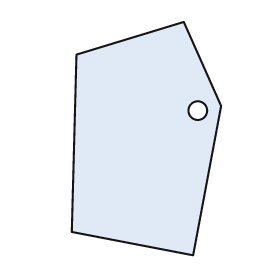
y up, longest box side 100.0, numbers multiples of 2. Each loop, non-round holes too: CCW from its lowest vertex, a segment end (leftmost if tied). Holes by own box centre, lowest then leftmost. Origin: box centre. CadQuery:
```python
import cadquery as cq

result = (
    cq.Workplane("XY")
    .moveTo(20.0, -50.0)
    .lineTo(32.0, 14.0)
    .lineTo(16.0, 50.0)
    .lineTo(-30.0, 36.0)
    .lineTo(-32.0, -40.0)
    .close()
    .moveTo(22.0, 12.0)
    .circle(4.0)
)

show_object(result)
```